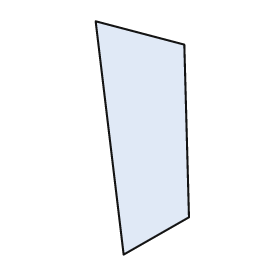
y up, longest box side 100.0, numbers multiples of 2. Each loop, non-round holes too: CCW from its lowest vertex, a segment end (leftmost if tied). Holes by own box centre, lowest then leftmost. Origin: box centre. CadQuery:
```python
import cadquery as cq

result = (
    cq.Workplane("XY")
    .moveTo(-8.0, -50.0)
    .lineTo(20.0, -34.0)
    .lineTo(18.0, 40.0)
    .lineTo(-20.0, 50.0)
    .close()
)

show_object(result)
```